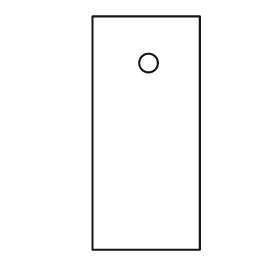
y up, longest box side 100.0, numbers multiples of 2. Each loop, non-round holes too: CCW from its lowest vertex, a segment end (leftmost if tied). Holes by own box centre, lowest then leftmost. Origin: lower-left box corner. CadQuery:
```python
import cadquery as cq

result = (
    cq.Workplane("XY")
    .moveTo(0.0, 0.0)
    .lineTo(46.0, 0.0)
    .lineTo(46.0, 100.0)
    .lineTo(0.0, 100.0)
    .close()
    .moveTo(24.0, 80.0)
    .circle(4.0)
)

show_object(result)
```